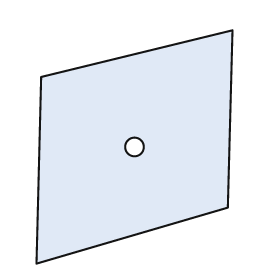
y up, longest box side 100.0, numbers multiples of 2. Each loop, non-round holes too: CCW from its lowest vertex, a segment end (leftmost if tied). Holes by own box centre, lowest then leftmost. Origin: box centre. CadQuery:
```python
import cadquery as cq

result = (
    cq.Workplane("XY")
    .moveTo(-42.0, -50.0)
    .lineTo(40.0, -26.0)
    .lineTo(42.0, 50.0)
    .lineTo(-40.0, 30.0)
    .close()
    .moveTo(0.0, 0.0)
    .circle(4.0)
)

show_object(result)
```